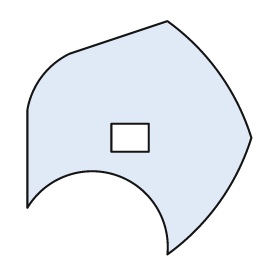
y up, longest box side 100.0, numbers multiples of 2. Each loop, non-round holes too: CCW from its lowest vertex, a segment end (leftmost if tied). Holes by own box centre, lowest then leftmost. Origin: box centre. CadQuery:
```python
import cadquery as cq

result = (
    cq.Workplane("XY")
    .moveTo(12.0, -50.0)
    .threePointArc((34.0, -28.0), (48.0, 0.0))
    .threePointArc((34.0, 28.0), (12.0, 50.0))
    .lineTo(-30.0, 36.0)
    .threePointArc((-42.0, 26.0), (-48.0, 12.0))
    .lineTo(-48.0, -30.0)
    .threePointArc((-10.0, -16.0), (12.0, -50.0))
    .close()
    .moveTo(-12.0, -6.0)
    .lineTo(4.0, -6.0)
    .lineTo(4.0, 6.0)
    .lineTo(-12.0, 6.0)
    .close()
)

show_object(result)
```